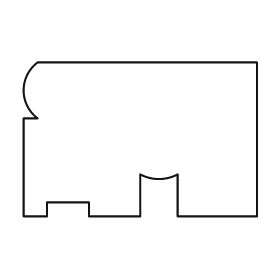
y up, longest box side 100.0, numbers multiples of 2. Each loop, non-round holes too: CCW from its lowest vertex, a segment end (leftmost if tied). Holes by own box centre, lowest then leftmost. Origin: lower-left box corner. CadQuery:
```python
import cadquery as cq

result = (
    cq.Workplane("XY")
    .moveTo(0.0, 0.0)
    .lineTo(10.0, 0.0)
    .lineTo(10.0, 6.0)
    .lineTo(28.0, 6.0)
    .lineTo(28.0, 0.0)
    .lineTo(50.0, 0.0)
    .lineTo(50.0, 18.0)
    .threePointArc((58.0, 16.0), (66.0, 18.0))
    .lineTo(66.0, 0.0)
    .lineTo(100.0, 0.0)
    .lineTo(100.0, 66.0)
    .lineTo(6.0, 66.0)
    .threePointArc((0.0, 54.0), (6.0, 42.0))
    .lineTo(0.0, 42.0)
    .close()
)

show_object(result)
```